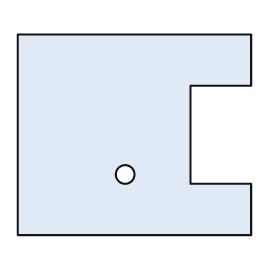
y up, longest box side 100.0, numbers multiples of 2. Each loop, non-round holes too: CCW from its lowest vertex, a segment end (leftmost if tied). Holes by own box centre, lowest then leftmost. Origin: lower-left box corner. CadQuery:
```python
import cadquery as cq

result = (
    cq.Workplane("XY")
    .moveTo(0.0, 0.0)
    .lineTo(100.0, 0.0)
    .lineTo(100.0, 22.0)
    .lineTo(74.0, 22.0)
    .lineTo(74.0, 64.0)
    .lineTo(100.0, 64.0)
    .lineTo(100.0, 86.0)
    .lineTo(0.0, 86.0)
    .close()
    .moveTo(46.0, 26.0)
    .circle(4.0)
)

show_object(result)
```